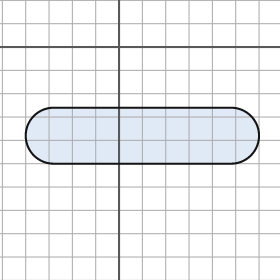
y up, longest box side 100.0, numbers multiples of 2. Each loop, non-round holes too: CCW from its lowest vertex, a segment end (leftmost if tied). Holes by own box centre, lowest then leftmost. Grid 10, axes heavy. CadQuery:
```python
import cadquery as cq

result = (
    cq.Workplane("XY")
    .moveTo(-28.0, -50.0)
    .lineTo(48.0, -50.0)
    .threePointArc((60.0, -38.0), (48.0, -26.0))
    .lineTo(-28.0, -26.0)
    .threePointArc((-40.0, -38.0), (-28.0, -50.0))
    .close()
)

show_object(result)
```